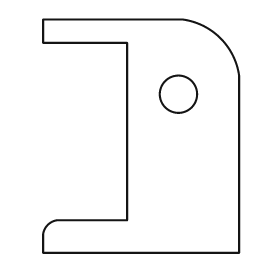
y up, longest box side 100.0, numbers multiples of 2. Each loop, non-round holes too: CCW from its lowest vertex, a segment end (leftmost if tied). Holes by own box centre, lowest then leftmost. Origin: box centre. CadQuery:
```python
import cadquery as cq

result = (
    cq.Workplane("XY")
    .moveTo(-42.0, -50.0)
    .lineTo(42.0, -50.0)
    .lineTo(42.0, 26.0)
    .threePointArc((34.0, 42.0), (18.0, 50.0))
    .lineTo(-42.0, 50.0)
    .lineTo(-42.0, 40.0)
    .lineTo(-6.0, 40.0)
    .lineTo(-6.0, -36.0)
    .lineTo(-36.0, -36.0)
    .threePointArc((-40.0, -38.0), (-42.0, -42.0))
    .close()
    .moveTo(16.0, 18.0)
    .circle(8.0)
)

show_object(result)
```